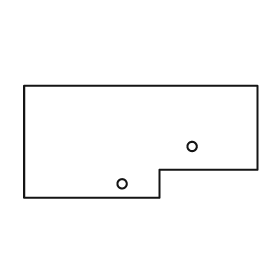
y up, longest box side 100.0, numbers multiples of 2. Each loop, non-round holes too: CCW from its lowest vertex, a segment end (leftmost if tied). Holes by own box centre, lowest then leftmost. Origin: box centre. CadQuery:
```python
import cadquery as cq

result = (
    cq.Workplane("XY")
    .moveTo(-50.0, -24.0)
    .lineTo(8.0, -24.0)
    .lineTo(8.0, -12.0)
    .lineTo(50.0, -12.0)
    .lineTo(50.0, 24.0)
    .lineTo(-50.0, 24.0)
    .close()
    .moveTo(-8.0, -18.0)
    .circle(2.0)
    .moveTo(22.0, -2.0)
    .circle(2.0)
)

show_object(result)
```